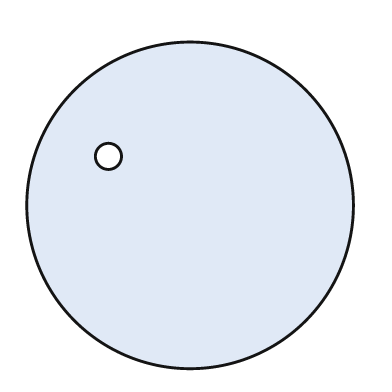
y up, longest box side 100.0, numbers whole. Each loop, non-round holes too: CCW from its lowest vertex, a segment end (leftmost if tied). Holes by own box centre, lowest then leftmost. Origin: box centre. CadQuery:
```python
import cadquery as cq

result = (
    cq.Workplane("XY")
    .moveTo(0.0, 0.0)
    .circle(50.0)
    .moveTo(-25.0, 15.0)
    .circle(4.0)
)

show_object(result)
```